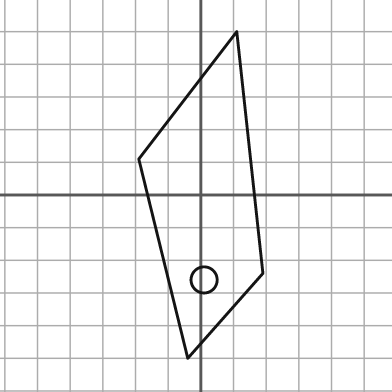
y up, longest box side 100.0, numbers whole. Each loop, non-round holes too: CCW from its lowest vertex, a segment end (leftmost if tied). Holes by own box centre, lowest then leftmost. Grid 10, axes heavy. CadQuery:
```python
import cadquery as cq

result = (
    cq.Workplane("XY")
    .moveTo(-4.0, -50.0)
    .lineTo(19.0, -24.0)
    .lineTo(11.0, 50.0)
    .lineTo(-19.0, 11.0)
    .close()
    .moveTo(1.0, -26.0)
    .circle(4.0)
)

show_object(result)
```